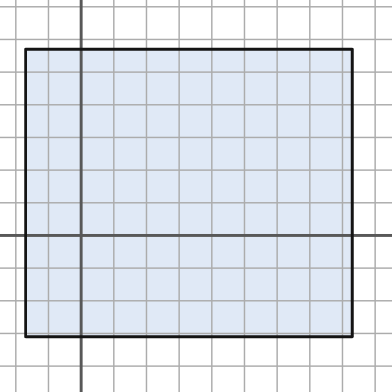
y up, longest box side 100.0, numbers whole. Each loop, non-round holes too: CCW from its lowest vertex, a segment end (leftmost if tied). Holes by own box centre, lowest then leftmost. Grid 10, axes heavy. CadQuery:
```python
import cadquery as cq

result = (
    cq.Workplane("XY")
    .moveTo(-17.0, -31.0)
    .lineTo(83.0, -31.0)
    .lineTo(83.0, 57.0)
    .lineTo(-17.0, 57.0)
    .close()
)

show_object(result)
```